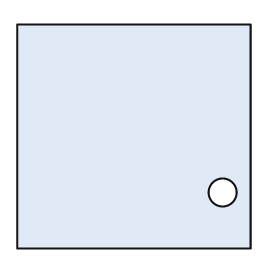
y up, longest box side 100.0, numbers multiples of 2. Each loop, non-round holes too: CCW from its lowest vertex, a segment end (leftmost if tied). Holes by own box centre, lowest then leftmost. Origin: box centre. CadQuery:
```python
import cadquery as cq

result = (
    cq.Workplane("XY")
    .moveTo(-50.0, -48.0)
    .lineTo(50.0, -48.0)
    .lineTo(50.0, 48.0)
    .lineTo(-50.0, 48.0)
    .close()
    .moveTo(38.0, -24.0)
    .circle(6.0)
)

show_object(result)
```